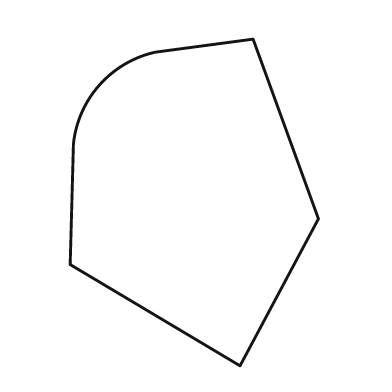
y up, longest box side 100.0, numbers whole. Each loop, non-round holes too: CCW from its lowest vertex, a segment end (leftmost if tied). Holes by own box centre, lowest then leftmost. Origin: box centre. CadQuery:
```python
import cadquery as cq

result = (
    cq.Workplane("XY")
    .moveTo(14.0, -50.0)
    .lineTo(38.0, -5.0)
    .lineTo(18.0, 50.0)
    .lineTo(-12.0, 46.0)
    .threePointArc((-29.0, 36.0), (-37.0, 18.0))
    .lineTo(-38.0, -19.0)
    .close()
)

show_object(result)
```